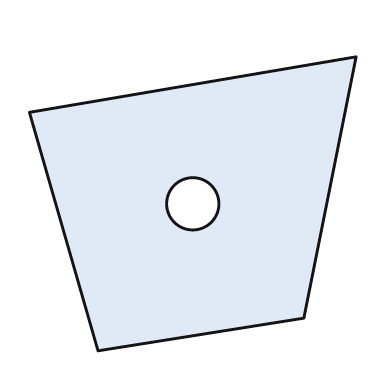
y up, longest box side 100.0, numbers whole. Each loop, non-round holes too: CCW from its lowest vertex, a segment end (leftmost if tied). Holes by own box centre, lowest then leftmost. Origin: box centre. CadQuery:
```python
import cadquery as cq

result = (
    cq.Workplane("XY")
    .moveTo(-29.0, -45.0)
    .lineTo(34.0, -35.0)
    .lineTo(50.0, 45.0)
    .lineTo(-50.0, 28.0)
    .close()
    .moveTo(0.0, 0.0)
    .circle(8.0)
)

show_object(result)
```